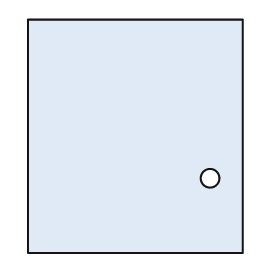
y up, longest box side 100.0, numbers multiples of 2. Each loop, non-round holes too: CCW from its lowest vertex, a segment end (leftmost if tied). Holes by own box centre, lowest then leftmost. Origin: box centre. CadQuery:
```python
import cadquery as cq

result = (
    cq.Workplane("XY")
    .moveTo(-46.0, -50.0)
    .lineTo(46.0, -50.0)
    .lineTo(46.0, 50.0)
    .lineTo(-46.0, 50.0)
    .close()
    .moveTo(32.0, -18.0)
    .circle(4.0)
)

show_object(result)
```